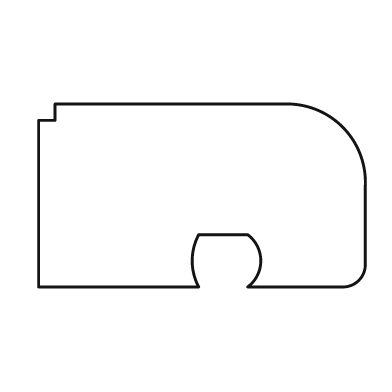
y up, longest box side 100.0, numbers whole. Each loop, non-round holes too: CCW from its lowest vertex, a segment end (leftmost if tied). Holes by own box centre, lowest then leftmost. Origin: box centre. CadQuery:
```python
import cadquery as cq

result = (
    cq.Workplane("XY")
    .moveTo(-50.0, -28.0)
    .lineTo(-1.0, -28.0)
    .threePointArc((-3.0, -20.0), (-1.0, -12.0))
    .lineTo(14.0, -12.0)
    .threePointArc((18.0, -20.0), (14.0, -28.0))
    .lineTo(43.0, -28.0)
    .threePointArc((48.0, -26.0), (50.0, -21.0))
    .lineTo(50.0, 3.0)
    .threePointArc((43.0, 21.0), (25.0, 28.0))
    .lineTo(-45.0, 28.0)
    .lineTo(-45.0, 23.0)
    .lineTo(-50.0, 23.0)
    .close()
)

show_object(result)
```